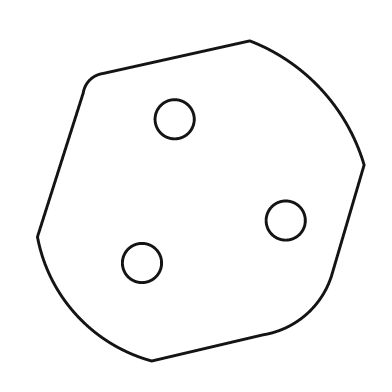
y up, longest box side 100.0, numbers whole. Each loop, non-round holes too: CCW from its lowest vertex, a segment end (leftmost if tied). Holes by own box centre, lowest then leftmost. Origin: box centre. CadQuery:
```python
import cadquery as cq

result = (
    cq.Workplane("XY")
    .moveTo(-15.0, -49.0)
    .lineTo(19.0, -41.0)
    .threePointArc((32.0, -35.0), (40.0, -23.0))
    .lineTo(50.0, 11.0)
    .threePointArc((37.0, 34.0), (15.0, 49.0))
    .lineTo(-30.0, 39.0)
    .threePointArc((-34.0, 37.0), (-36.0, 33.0))
    .lineTo(-50.0, -11.0)
    .threePointArc((-38.0, -35.0), (-15.0, -49.0))
    .close()
    .moveTo(-18.0, -19.0)
    .circle(6.0)
    .moveTo(26.0, -6.0)
    .circle(6.0)
    .moveTo(-8.0, 25.0)
    .circle(6.0)
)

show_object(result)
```